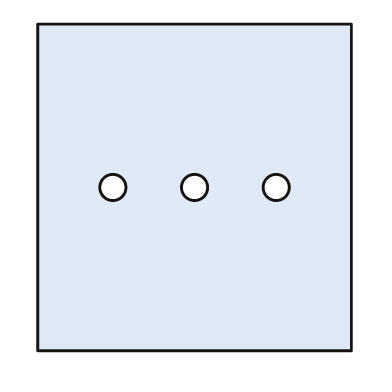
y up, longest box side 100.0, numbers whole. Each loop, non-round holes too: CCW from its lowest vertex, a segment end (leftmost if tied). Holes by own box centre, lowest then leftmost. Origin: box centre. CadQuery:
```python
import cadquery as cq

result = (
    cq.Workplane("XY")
    .moveTo(-48.0, -50.0)
    .lineTo(48.0, -50.0)
    .lineTo(48.0, 50.0)
    .lineTo(-48.0, 50.0)
    .close()
    .moveTo(-25.0, 0.0)
    .circle(4.0)
    .moveTo(0.0, 0.0)
    .circle(4.0)
    .moveTo(25.0, 0.0)
    .circle(4.0)
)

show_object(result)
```